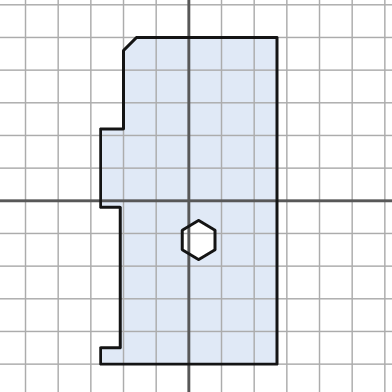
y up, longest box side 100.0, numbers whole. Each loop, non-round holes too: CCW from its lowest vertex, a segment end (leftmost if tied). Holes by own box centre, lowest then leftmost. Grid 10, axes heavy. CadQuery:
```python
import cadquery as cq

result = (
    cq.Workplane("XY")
    .moveTo(-27.0, -50.0)
    .lineTo(27.0, -50.0)
    .lineTo(27.0, 50.0)
    .lineTo(-16.0, 50.0)
    .lineTo(-20.0, 46.0)
    .lineTo(-20.0, 22.0)
    .lineTo(-27.0, 22.0)
    .lineTo(-27.0, -2.0)
    .lineTo(-21.0, -2.0)
    .lineTo(-21.0, -45.0)
    .lineTo(-27.0, -45.0)
    .close()
    .moveTo(3.0, -18.0)
    .lineTo(8.0, -15.0)
    .lineTo(8.0, -9.0)
    .lineTo(3.0, -6.0)
    .lineTo(-2.0, -9.0)
    .lineTo(-2.0, -15.0)
    .close()
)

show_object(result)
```